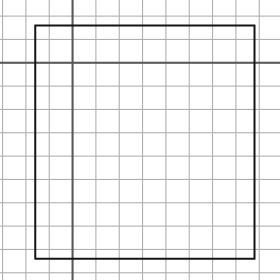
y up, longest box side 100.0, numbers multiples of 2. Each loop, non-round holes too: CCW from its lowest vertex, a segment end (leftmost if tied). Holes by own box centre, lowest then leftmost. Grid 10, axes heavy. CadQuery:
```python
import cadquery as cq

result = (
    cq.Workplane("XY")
    .moveTo(-16.0, -84.0)
    .lineTo(78.0, -84.0)
    .lineTo(78.0, 16.0)
    .lineTo(-16.0, 16.0)
    .close()
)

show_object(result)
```